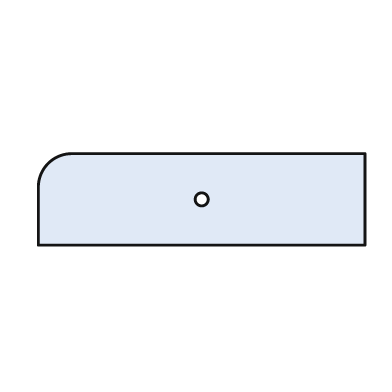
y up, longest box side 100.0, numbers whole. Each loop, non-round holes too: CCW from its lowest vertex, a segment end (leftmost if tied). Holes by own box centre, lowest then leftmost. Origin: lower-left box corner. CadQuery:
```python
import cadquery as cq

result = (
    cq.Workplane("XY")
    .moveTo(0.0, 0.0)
    .lineTo(100.0, 0.0)
    .lineTo(100.0, 28.0)
    .lineTo(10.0, 28.0)
    .threePointArc((3.0, 25.0), (0.0, 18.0))
    .close()
    .moveTo(50.0, 14.0)
    .circle(2.0)
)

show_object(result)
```